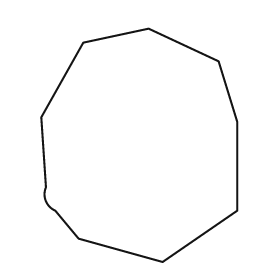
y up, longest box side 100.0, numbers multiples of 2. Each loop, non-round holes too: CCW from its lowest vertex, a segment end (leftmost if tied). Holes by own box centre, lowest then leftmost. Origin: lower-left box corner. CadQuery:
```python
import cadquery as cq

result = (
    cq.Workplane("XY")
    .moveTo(52.0, 0.0)
    .lineTo(84.0, 22.0)
    .lineTo(84.0, 60.0)
    .lineTo(76.0, 86.0)
    .lineTo(46.0, 100.0)
    .lineTo(18.0, 94.0)
    .lineTo(0.0, 62.0)
    .lineTo(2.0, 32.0)
    .threePointArc((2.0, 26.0), (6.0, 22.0))
    .lineTo(16.0, 10.0)
    .close()
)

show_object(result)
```